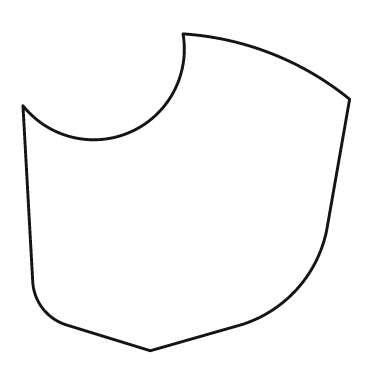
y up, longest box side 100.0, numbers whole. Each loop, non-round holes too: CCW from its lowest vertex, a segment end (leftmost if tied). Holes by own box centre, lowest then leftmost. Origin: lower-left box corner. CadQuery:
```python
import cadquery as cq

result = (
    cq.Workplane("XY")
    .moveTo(39.0, 0.0)
    .lineTo(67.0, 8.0)
    .threePointArc((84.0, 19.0), (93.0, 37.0))
    .lineTo(100.0, 77.0)
    .threePointArc((76.0, 91.0), (49.0, 97.0))
    .threePointArc((33.0, 67.0), (0.0, 75.0))
    .lineTo(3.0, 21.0)
    .threePointArc((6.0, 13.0), (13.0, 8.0))
    .close()
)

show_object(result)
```